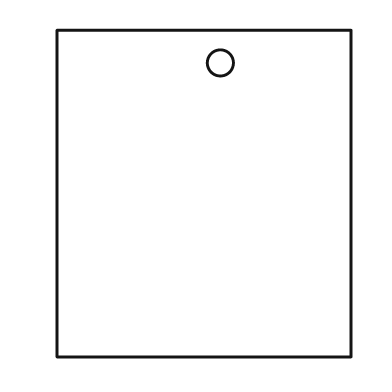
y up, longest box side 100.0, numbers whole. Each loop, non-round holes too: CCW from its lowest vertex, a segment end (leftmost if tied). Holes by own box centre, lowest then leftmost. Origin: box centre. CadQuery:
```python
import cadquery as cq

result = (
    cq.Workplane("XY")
    .moveTo(-45.0, -50.0)
    .lineTo(45.0, -50.0)
    .lineTo(45.0, 50.0)
    .lineTo(-45.0, 50.0)
    .close()
    .moveTo(5.0, 40.0)
    .circle(4.0)
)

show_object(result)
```